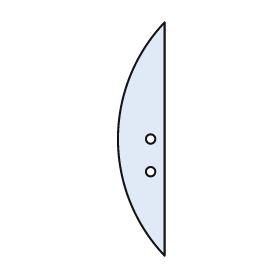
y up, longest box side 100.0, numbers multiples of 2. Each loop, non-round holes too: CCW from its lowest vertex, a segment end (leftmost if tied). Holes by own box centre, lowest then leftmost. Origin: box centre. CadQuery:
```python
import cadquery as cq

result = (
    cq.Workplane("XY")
    .moveTo(10.0, -50.0)
    .lineTo(10.0, 50.0)
    .threePointArc((-10.0, 0.0), (10.0, -50.0))
    .close()
    .moveTo(4.0, -14.0)
    .circle(2.0)
    .moveTo(4.0, 0.0)
    .circle(2.0)
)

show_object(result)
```